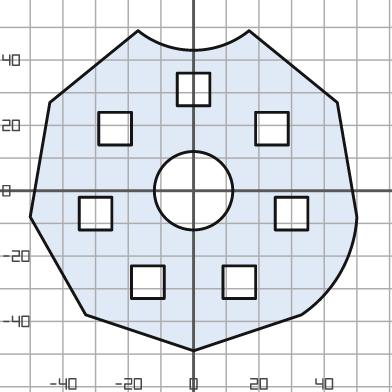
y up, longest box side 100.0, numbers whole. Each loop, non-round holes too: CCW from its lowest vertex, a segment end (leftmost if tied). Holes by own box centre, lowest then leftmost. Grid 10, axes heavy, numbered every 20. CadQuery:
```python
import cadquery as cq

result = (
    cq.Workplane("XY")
    .moveTo(0.0, -49.0)
    .lineTo(33.0, -38.0)
    .threePointArc((45.0, -25.0), (50.0, -8.0))
    .lineTo(44.0, 27.0)
    .lineTo(17.0, 49.0)
    .threePointArc((0.0, 43.0), (-17.0, 49.0))
    .lineTo(-44.0, 27.0)
    .lineTo(-50.0, -8.0)
    .lineTo(-33.0, -38.0)
    .close()
    .moveTo(-19.0, -33.0)
    .lineTo(-9.0, -33.0)
    .lineTo(-9.0, -23.0)
    .lineTo(-19.0, -23.0)
    .close()
    .moveTo(9.0, -33.0)
    .lineTo(19.0, -33.0)
    .lineTo(19.0, -23.0)
    .lineTo(9.0, -23.0)
    .close()
    .moveTo(-35.0, -12.0)
    .lineTo(-25.0, -12.0)
    .lineTo(-25.0, -2.0)
    .lineTo(-35.0, -2.0)
    .close()
    .moveTo(25.0, -12.0)
    .lineTo(35.0, -12.0)
    .lineTo(35.0, -2.0)
    .lineTo(25.0, -2.0)
    .close()
    .moveTo(0.0, 0.0)
    .circle(12.0)
    .moveTo(-29.0, 14.0)
    .lineTo(-19.0, 14.0)
    .lineTo(-19.0, 24.0)
    .lineTo(-29.0, 24.0)
    .close()
    .moveTo(19.0, 14.0)
    .lineTo(29.0, 14.0)
    .lineTo(29.0, 24.0)
    .lineTo(19.0, 24.0)
    .close()
    .moveTo(-5.0, 26.0)
    .lineTo(5.0, 26.0)
    .lineTo(5.0, 36.0)
    .lineTo(-5.0, 36.0)
    .close()
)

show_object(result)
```